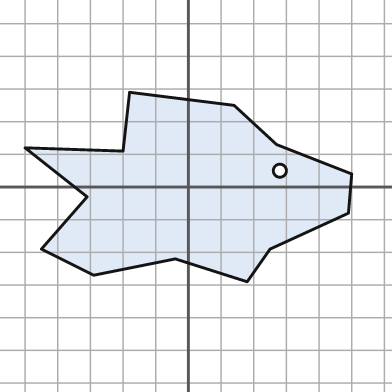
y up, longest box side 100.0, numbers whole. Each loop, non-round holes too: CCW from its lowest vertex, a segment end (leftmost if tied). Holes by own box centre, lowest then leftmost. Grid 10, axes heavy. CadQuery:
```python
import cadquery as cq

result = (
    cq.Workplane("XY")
    .moveTo(18.0, -29.0)
    .lineTo(25.0, -19.0)
    .lineTo(49.0, -8.0)
    .lineTo(50.0, 4.0)
    .lineTo(27.0, 13.0)
    .lineTo(14.0, 25.0)
    .lineTo(-18.0, 29.0)
    .lineTo(-20.0, 11.0)
    .lineTo(-50.0, 12.0)
    .lineTo(-31.0, -3.0)
    .lineTo(-45.0, -19.0)
    .lineTo(-29.0, -27.0)
    .lineTo(-4.0, -22.0)
    .close()
    .moveTo(28.0, 5.0)
    .circle(2.0)
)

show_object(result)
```